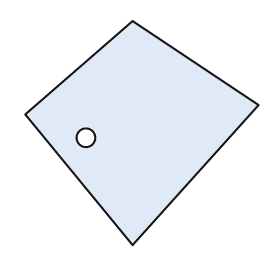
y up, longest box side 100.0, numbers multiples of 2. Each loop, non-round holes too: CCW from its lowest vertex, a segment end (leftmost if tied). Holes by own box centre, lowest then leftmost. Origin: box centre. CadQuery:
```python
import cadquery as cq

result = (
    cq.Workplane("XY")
    .moveTo(-4.0, -48.0)
    .lineTo(50.0, 12.0)
    .lineTo(-4.0, 48.0)
    .lineTo(-50.0, 8.0)
    .close()
    .moveTo(-24.0, -2.0)
    .circle(4.0)
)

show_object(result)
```